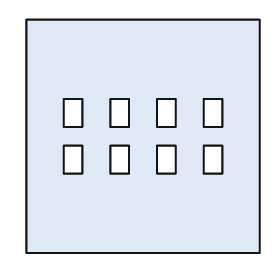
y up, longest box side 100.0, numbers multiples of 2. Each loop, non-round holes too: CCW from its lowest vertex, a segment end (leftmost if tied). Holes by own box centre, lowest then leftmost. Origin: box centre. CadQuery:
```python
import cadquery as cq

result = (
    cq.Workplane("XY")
    .moveTo(-50.0, -50.0)
    .lineTo(50.0, -50.0)
    .lineTo(50.0, 50.0)
    .lineTo(-50.0, 50.0)
    .close()
    .moveTo(-34.0, -16.0)
    .lineTo(-26.0, -16.0)
    .lineTo(-26.0, -4.0)
    .lineTo(-34.0, -4.0)
    .close()
    .moveTo(-14.0, -16.0)
    .lineTo(-6.0, -16.0)
    .lineTo(-6.0, -4.0)
    .lineTo(-14.0, -4.0)
    .close()
    .moveTo(6.0, -16.0)
    .lineTo(14.0, -16.0)
    .lineTo(14.0, -4.0)
    .lineTo(6.0, -4.0)
    .close()
    .moveTo(26.0, -16.0)
    .lineTo(34.0, -16.0)
    .lineTo(34.0, -4.0)
    .lineTo(26.0, -4.0)
    .close()
    .moveTo(-34.0, 4.0)
    .lineTo(-26.0, 4.0)
    .lineTo(-26.0, 16.0)
    .lineTo(-34.0, 16.0)
    .close()
    .moveTo(-14.0, 4.0)
    .lineTo(-6.0, 4.0)
    .lineTo(-6.0, 16.0)
    .lineTo(-14.0, 16.0)
    .close()
    .moveTo(6.0, 4.0)
    .lineTo(14.0, 4.0)
    .lineTo(14.0, 16.0)
    .lineTo(6.0, 16.0)
    .close()
    .moveTo(26.0, 4.0)
    .lineTo(34.0, 4.0)
    .lineTo(34.0, 16.0)
    .lineTo(26.0, 16.0)
    .close()
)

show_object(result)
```